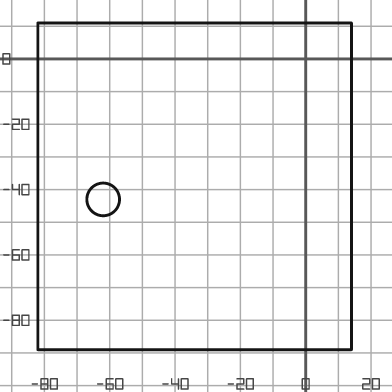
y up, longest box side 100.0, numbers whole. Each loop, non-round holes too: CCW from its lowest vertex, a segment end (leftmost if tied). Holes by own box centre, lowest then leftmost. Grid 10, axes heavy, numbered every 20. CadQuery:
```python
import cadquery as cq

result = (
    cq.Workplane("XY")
    .moveTo(-82.0, -89.0)
    .lineTo(14.0, -89.0)
    .lineTo(14.0, 11.0)
    .lineTo(-82.0, 11.0)
    .close()
    .moveTo(-62.0, -43.0)
    .circle(5.0)
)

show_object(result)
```